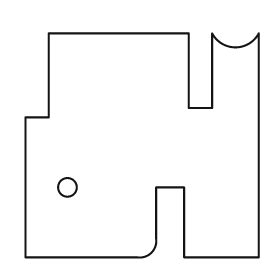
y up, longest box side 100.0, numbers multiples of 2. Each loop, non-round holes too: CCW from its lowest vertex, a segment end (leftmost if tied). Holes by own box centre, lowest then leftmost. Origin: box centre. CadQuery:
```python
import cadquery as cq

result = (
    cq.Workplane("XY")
    .moveTo(-50.0, -48.0)
    .lineTo(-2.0, -48.0)
    .threePointArc((4.0, -46.0), (6.0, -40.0))
    .lineTo(6.0, -18.0)
    .lineTo(18.0, -18.0)
    .lineTo(18.0, -48.0)
    .lineTo(50.0, -48.0)
    .lineTo(50.0, 48.0)
    .threePointArc((40.0, 42.0), (30.0, 48.0))
    .lineTo(30.0, 16.0)
    .lineTo(20.0, 16.0)
    .lineTo(20.0, 48.0)
    .lineTo(-40.0, 48.0)
    .lineTo(-40.0, 12.0)
    .lineTo(-50.0, 12.0)
    .close()
    .moveTo(-32.0, -18.0)
    .circle(4.0)
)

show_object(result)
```